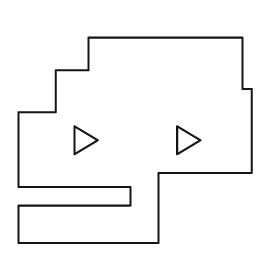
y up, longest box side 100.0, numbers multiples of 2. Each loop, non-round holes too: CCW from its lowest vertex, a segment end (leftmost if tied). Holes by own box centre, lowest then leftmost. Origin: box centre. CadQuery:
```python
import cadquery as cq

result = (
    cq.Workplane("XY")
    .moveTo(-50.0, -44.0)
    .lineTo(10.0, -44.0)
    .lineTo(10.0, -14.0)
    .lineTo(50.0, -14.0)
    .lineTo(50.0, 22.0)
    .lineTo(46.0, 22.0)
    .lineTo(46.0, 44.0)
    .lineTo(-20.0, 44.0)
    .lineTo(-20.0, 30.0)
    .lineTo(-34.0, 30.0)
    .lineTo(-34.0, 12.0)
    .lineTo(-50.0, 12.0)
    .lineTo(-50.0, -20.0)
    .lineTo(-2.0, -20.0)
    .lineTo(-2.0, -28.0)
    .lineTo(-50.0, -28.0)
    .close()
    .moveTo(-26.0, -6.0)
    .lineTo(-16.0, 0.0)
    .lineTo(-26.0, 6.0)
    .close()
    .moveTo(18.0, -6.0)
    .lineTo(28.0, 0.0)
    .lineTo(18.0, 6.0)
    .close()
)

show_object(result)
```